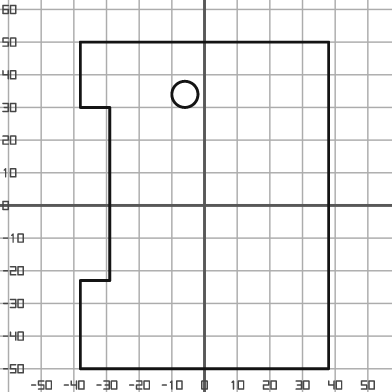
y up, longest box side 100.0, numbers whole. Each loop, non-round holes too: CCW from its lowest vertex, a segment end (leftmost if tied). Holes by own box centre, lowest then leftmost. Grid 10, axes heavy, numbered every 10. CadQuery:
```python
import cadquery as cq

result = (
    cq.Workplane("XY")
    .moveTo(-38.0, -50.0)
    .lineTo(38.0, -50.0)
    .lineTo(38.0, 50.0)
    .lineTo(-38.0, 50.0)
    .lineTo(-38.0, 30.0)
    .lineTo(-29.0, 30.0)
    .lineTo(-29.0, -23.0)
    .lineTo(-38.0, -23.0)
    .close()
    .moveTo(-6.0, 34.0)
    .circle(4.0)
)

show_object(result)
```